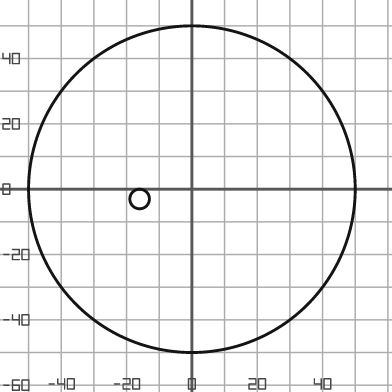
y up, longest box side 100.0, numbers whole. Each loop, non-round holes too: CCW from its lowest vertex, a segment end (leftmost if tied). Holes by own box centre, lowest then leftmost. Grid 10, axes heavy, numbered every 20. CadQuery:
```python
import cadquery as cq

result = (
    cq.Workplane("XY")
    .moveTo(0.0, 0.0)
    .circle(50.0)
    .moveTo(-16.0, -3.0)
    .circle(3.0)
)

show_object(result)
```